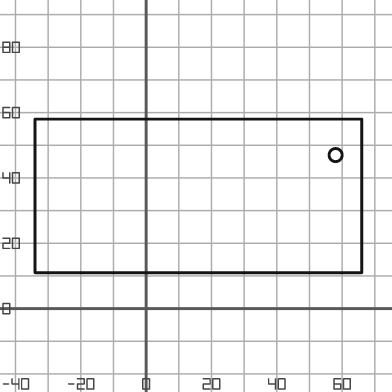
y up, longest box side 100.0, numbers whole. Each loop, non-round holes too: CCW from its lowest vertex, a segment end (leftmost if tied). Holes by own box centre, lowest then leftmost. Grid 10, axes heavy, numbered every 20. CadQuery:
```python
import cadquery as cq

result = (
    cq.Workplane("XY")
    .moveTo(-34.0, 11.0)
    .lineTo(66.0, 11.0)
    .lineTo(66.0, 58.0)
    .lineTo(-34.0, 58.0)
    .close()
    .moveTo(58.0, 47.0)
    .circle(2.0)
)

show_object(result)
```